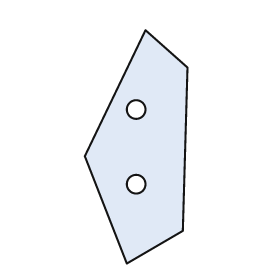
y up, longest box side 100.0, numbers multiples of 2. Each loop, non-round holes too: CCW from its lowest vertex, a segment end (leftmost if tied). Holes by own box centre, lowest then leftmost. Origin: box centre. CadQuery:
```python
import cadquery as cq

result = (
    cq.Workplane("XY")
    .moveTo(-4.0, -50.0)
    .lineTo(20.0, -36.0)
    .lineTo(22.0, 34.0)
    .lineTo(4.0, 50.0)
    .lineTo(-22.0, -4.0)
    .close()
    .moveTo(0.0, -16.0)
    .circle(4.0)
    .moveTo(0.0, 16.0)
    .circle(4.0)
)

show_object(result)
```